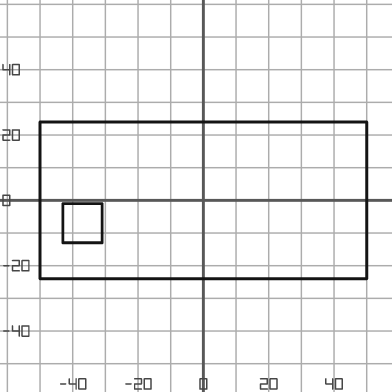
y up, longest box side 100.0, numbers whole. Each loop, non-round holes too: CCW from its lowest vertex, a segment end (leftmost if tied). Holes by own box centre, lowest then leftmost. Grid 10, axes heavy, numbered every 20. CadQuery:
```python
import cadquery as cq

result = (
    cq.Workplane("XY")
    .moveTo(-50.0, -24.0)
    .lineTo(50.0, -24.0)
    .lineTo(50.0, 24.0)
    .lineTo(-50.0, 24.0)
    .close()
    .moveTo(-43.0, -13.0)
    .lineTo(-31.0, -13.0)
    .lineTo(-31.0, -1.0)
    .lineTo(-43.0, -1.0)
    .close()
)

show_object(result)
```